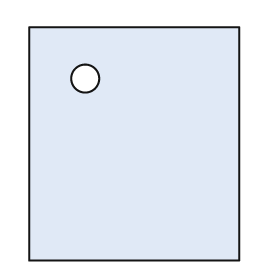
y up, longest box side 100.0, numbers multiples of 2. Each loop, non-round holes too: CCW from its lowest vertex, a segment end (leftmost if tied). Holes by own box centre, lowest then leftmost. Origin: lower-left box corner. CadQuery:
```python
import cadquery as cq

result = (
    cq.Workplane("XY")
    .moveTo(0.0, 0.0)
    .lineTo(90.0, 0.0)
    .lineTo(90.0, 100.0)
    .lineTo(0.0, 100.0)
    .close()
    .moveTo(24.0, 78.0)
    .circle(6.0)
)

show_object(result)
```